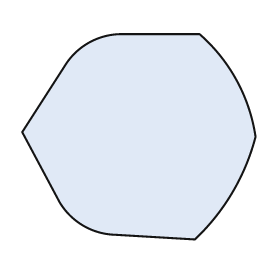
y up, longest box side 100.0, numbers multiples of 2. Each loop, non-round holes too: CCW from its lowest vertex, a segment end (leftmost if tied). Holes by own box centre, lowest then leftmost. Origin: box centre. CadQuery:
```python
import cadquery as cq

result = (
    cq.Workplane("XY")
    .moveTo(24.0, -44.0)
    .threePointArc((40.0, -24.0), (50.0, 0.0))
    .threePointArc((42.0, 24.0), (26.0, 44.0))
    .lineTo(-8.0, 44.0)
    .threePointArc((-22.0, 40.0), (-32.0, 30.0))
    .lineTo(-50.0, 2.0)
    .lineTo(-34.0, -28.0)
    .threePointArc((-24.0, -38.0), (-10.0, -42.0))
    .close()
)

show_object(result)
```